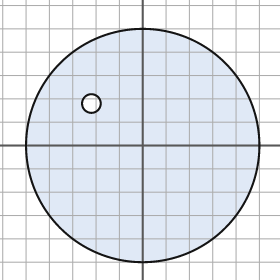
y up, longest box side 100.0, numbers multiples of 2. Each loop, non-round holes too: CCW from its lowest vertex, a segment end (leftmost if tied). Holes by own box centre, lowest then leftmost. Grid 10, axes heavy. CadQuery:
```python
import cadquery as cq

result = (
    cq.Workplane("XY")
    .moveTo(0.0, 0.0)
    .circle(50.0)
    .moveTo(-22.0, 18.0)
    .circle(4.0)
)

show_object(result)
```